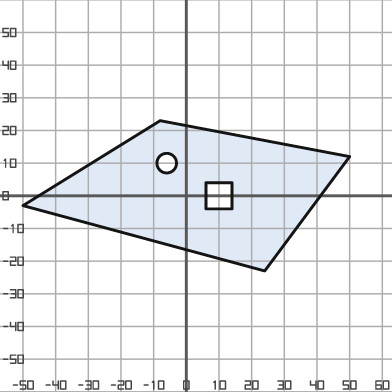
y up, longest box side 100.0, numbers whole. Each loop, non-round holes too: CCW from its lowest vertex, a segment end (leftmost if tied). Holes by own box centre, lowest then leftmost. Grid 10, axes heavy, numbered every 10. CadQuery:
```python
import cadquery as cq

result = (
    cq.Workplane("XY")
    .moveTo(24.0, -23.0)
    .lineTo(50.0, 12.0)
    .lineTo(-8.0, 23.0)
    .lineTo(-50.0, -3.0)
    .close()
    .moveTo(6.0, -4.0)
    .lineTo(14.0, -4.0)
    .lineTo(14.0, 4.0)
    .lineTo(6.0, 4.0)
    .close()
    .moveTo(-6.0, 10.0)
    .circle(3.0)
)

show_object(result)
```